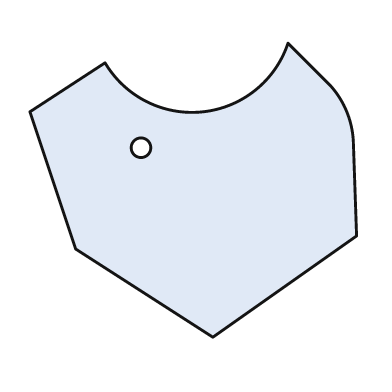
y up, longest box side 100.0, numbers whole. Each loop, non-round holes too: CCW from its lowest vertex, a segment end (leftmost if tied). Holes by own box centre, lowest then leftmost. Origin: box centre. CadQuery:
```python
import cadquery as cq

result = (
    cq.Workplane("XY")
    .moveTo(6.0, -45.0)
    .lineTo(50.0, -14.0)
    .lineTo(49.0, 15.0)
    .threePointArc((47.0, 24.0), (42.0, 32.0))
    .lineTo(29.0, 45.0)
    .threePointArc((3.0, 24.0), (-27.0, 39.0))
    .lineTo(-50.0, 24.0)
    .lineTo(-36.0, -18.0)
    .close()
    .moveTo(-16.0, 13.0)
    .circle(3.0)
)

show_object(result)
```